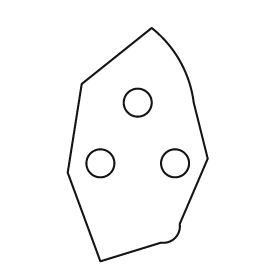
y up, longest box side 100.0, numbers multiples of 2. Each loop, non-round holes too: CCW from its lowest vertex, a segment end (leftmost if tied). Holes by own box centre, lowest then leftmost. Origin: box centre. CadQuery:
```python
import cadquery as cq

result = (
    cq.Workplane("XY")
    .moveTo(-16.0, -50.0)
    .lineTo(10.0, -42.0)
    .threePointArc((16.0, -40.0), (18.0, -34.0))
    .lineTo(30.0, -6.0)
    .lineTo(24.0, 18.0)
    .threePointArc((18.0, 36.0), (6.0, 50.0))
    .lineTo(-24.0, 26.0)
    .lineTo(-30.0, -12.0)
    .close()
    .moveTo(-16.0, -8.0)
    .circle(6.0)
    .moveTo(16.0, -8.0)
    .circle(6.0)
    .moveTo(0.0, 18.0)
    .circle(6.0)
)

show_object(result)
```